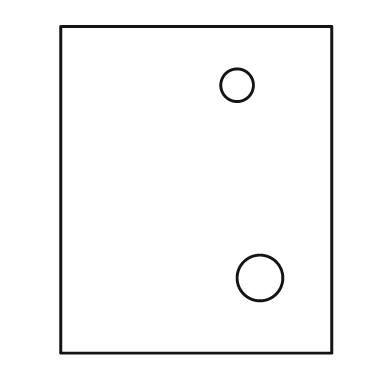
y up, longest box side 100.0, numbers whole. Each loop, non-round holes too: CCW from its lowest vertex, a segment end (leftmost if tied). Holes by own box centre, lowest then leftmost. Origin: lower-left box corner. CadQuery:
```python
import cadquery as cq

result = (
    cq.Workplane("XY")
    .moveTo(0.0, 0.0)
    .lineTo(83.0, 0.0)
    .lineTo(83.0, 100.0)
    .lineTo(0.0, 100.0)
    .close()
    .moveTo(61.0, 23.0)
    .circle(7.0)
    .moveTo(54.0, 82.0)
    .circle(5.0)
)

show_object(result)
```